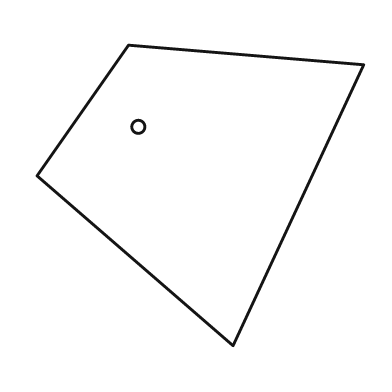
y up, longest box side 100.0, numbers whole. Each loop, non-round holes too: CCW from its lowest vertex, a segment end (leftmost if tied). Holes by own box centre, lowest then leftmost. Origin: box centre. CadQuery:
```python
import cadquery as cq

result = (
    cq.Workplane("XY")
    .moveTo(10.0, -46.0)
    .lineTo(50.0, 40.0)
    .lineTo(-22.0, 46.0)
    .lineTo(-50.0, 6.0)
    .close()
    .moveTo(-19.0, 21.0)
    .circle(2.0)
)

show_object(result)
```